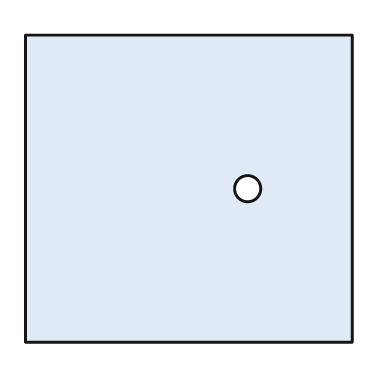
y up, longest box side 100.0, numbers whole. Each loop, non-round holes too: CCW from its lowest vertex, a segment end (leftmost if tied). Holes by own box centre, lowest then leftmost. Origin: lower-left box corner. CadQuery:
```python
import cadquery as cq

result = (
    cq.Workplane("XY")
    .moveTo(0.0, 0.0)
    .lineTo(100.0, 0.0)
    .lineTo(100.0, 94.0)
    .lineTo(0.0, 94.0)
    .close()
    .moveTo(68.0, 47.0)
    .circle(4.0)
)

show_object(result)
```